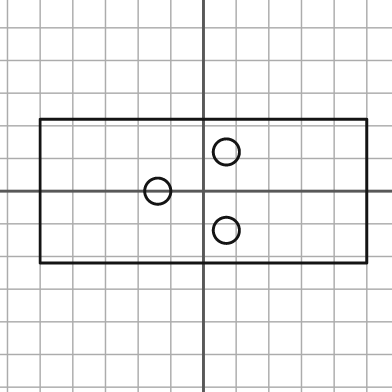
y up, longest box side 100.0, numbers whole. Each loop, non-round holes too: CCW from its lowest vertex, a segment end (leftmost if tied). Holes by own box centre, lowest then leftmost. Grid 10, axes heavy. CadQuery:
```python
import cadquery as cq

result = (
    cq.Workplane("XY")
    .moveTo(-50.0, -22.0)
    .lineTo(50.0, -22.0)
    .lineTo(50.0, 22.0)
    .lineTo(-50.0, 22.0)
    .close()
    .moveTo(7.0, -12.0)
    .circle(4.0)
    .moveTo(-14.0, 0.0)
    .circle(4.0)
    .moveTo(7.0, 12.0)
    .circle(4.0)
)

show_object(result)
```